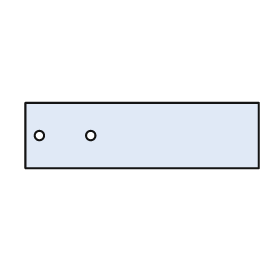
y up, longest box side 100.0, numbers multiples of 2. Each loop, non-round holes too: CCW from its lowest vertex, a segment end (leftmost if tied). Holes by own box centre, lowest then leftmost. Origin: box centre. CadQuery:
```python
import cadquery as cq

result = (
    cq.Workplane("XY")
    .moveTo(-50.0, -14.0)
    .lineTo(50.0, -14.0)
    .lineTo(50.0, 14.0)
    .lineTo(-50.0, 14.0)
    .close()
    .moveTo(-44.0, 0.0)
    .circle(2.0)
    .moveTo(-22.0, 0.0)
    .circle(2.0)
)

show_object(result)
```